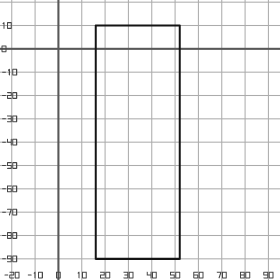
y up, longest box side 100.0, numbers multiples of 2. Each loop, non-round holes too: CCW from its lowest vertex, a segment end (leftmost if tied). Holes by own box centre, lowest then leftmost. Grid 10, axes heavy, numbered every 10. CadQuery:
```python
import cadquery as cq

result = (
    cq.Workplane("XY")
    .moveTo(16.0, -90.0)
    .lineTo(52.0, -90.0)
    .lineTo(52.0, 10.0)
    .lineTo(16.0, 10.0)
    .close()
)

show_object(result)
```